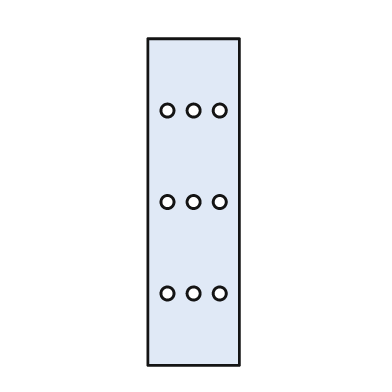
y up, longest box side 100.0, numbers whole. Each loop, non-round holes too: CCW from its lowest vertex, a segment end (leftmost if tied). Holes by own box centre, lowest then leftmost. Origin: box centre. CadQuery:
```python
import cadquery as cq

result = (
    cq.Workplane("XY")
    .moveTo(-14.0, -50.0)
    .lineTo(14.0, -50.0)
    .lineTo(14.0, 50.0)
    .lineTo(-14.0, 50.0)
    .close()
    .moveTo(-8.0, -28.0)
    .circle(2.0)
    .moveTo(0.0, -28.0)
    .circle(2.0)
    .moveTo(8.0, -28.0)
    .circle(2.0)
    .moveTo(-8.0, 0.0)
    .circle(2.0)
    .moveTo(0.0, 0.0)
    .circle(2.0)
    .moveTo(8.0, 0.0)
    .circle(2.0)
    .moveTo(-8.0, 28.0)
    .circle(2.0)
    .moveTo(0.0, 28.0)
    .circle(2.0)
    .moveTo(8.0, 28.0)
    .circle(2.0)
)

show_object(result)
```